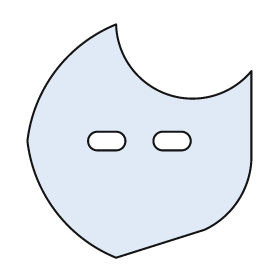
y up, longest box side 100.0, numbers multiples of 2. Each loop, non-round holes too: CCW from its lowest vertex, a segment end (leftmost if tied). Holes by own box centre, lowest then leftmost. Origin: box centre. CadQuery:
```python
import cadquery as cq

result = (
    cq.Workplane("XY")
    .moveTo(-10.0, -50.0)
    .lineTo(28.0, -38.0)
    .threePointArc((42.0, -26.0), (48.0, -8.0))
    .lineTo(48.0, 30.0)
    .threePointArc((12.0, 20.0), (-10.0, 50.0))
    .threePointArc((-36.0, 30.0), (-48.0, 0.0))
    .threePointArc((-36.0, -30.0), (-10.0, -50.0))
    .close()
    .moveTo(-18.0, -4.0)
    .lineTo(-10.0, -4.0)
    .threePointArc((-6.0, 0.0), (-10.0, 4.0))
    .lineTo(-18.0, 4.0)
    .threePointArc((-22.0, 0.0), (-18.0, -4.0))
    .close()
    .moveTo(10.0, -4.0)
    .lineTo(18.0, -4.0)
    .threePointArc((22.0, 0.0), (18.0, 4.0))
    .lineTo(10.0, 4.0)
    .threePointArc((6.0, 0.0), (10.0, -4.0))
    .close()
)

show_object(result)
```